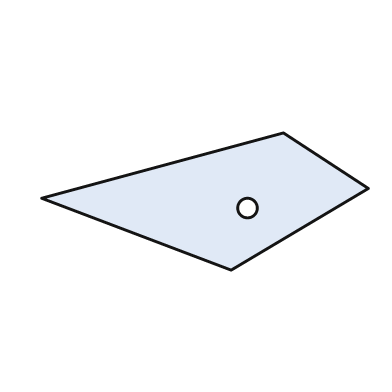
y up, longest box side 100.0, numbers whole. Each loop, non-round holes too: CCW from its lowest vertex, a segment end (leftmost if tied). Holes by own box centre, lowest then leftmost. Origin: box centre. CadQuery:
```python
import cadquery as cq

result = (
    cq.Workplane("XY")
    .moveTo(8.0, -21.0)
    .lineTo(50.0, 4.0)
    .lineTo(24.0, 21.0)
    .lineTo(-50.0, 1.0)
    .close()
    .moveTo(13.0, -2.0)
    .circle(3.0)
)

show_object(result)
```